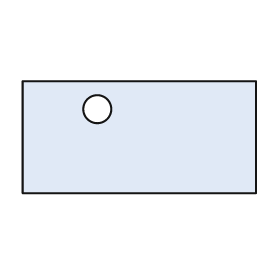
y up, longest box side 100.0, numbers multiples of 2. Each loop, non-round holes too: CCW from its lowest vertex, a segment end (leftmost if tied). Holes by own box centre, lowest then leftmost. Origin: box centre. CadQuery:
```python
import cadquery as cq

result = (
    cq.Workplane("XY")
    .moveTo(-50.0, -24.0)
    .lineTo(50.0, -24.0)
    .lineTo(50.0, 24.0)
    .lineTo(-50.0, 24.0)
    .close()
    .moveTo(-18.0, 12.0)
    .circle(6.0)
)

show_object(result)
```